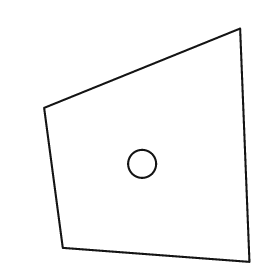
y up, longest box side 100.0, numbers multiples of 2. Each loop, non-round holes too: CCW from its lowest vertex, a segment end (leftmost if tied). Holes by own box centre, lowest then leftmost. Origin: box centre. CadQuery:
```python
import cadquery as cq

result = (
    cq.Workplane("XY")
    .moveTo(44.0, -50.0)
    .lineTo(40.0, 50.0)
    .lineTo(-44.0, 16.0)
    .lineTo(-36.0, -44.0)
    .close()
    .moveTo(-2.0, -8.0)
    .circle(6.0)
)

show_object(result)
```